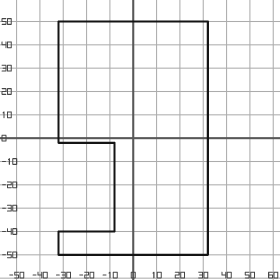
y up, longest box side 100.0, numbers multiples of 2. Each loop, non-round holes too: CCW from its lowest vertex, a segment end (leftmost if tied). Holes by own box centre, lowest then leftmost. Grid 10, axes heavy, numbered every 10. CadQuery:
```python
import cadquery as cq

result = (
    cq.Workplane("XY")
    .moveTo(-32.0, -50.0)
    .lineTo(32.0, -50.0)
    .lineTo(32.0, 50.0)
    .lineTo(-32.0, 50.0)
    .lineTo(-32.0, -2.0)
    .lineTo(-8.0, -2.0)
    .lineTo(-8.0, -40.0)
    .lineTo(-32.0, -40.0)
    .close()
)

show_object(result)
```